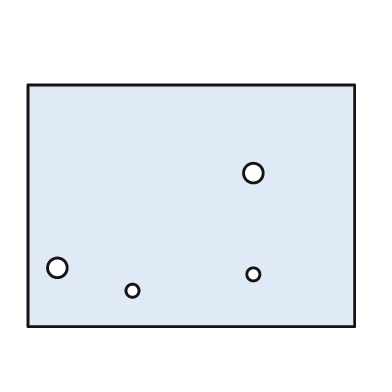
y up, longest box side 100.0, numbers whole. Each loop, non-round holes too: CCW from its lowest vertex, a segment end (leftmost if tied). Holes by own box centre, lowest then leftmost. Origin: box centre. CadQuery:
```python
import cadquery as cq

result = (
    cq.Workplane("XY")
    .moveTo(-50.0, -37.0)
    .lineTo(50.0, -37.0)
    .lineTo(50.0, 37.0)
    .lineTo(-50.0, 37.0)
    .close()
    .moveTo(-18.0, -26.0)
    .circle(2.0)
    .moveTo(19.0, -21.0)
    .circle(2.0)
    .moveTo(-41.0, -19.0)
    .circle(3.0)
    .moveTo(19.0, 10.0)
    .circle(3.0)
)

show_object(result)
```